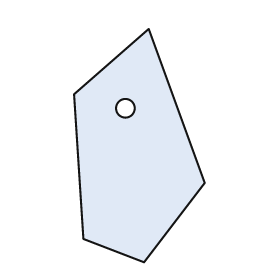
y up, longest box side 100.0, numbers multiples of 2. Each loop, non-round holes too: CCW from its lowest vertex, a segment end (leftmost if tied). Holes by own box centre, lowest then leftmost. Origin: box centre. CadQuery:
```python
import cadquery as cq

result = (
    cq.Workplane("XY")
    .moveTo(2.0, -50.0)
    .lineTo(28.0, -16.0)
    .lineTo(4.0, 50.0)
    .lineTo(-28.0, 22.0)
    .lineTo(-24.0, -40.0)
    .close()
    .moveTo(-6.0, 16.0)
    .circle(4.0)
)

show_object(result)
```